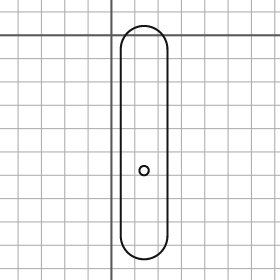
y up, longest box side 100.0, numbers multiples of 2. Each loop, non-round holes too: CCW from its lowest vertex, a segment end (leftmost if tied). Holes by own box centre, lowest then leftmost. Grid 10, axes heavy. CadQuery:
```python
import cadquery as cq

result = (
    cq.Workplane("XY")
    .moveTo(4.0, -86.0)
    .threePointArc((14.0, -96.0), (24.0, -86.0))
    .lineTo(24.0, -6.0)
    .threePointArc((14.0, 4.0), (4.0, -6.0))
    .close()
    .moveTo(14.0, -58.0)
    .circle(2.0)
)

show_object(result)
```